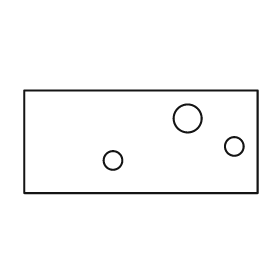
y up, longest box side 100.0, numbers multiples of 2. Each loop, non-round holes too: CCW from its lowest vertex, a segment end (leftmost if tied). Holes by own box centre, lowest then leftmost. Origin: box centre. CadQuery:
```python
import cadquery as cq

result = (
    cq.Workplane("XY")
    .moveTo(-50.0, -22.0)
    .lineTo(50.0, -22.0)
    .lineTo(50.0, 22.0)
    .lineTo(-50.0, 22.0)
    .close()
    .moveTo(-12.0, -8.0)
    .circle(4.0)
    .moveTo(40.0, -2.0)
    .circle(4.0)
    .moveTo(20.0, 10.0)
    .circle(6.0)
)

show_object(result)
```